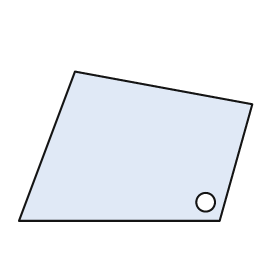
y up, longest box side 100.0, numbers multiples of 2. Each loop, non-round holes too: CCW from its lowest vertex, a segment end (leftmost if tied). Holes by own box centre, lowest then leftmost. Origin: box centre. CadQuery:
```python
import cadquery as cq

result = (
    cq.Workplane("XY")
    .moveTo(-50.0, -32.0)
    .lineTo(36.0, -32.0)
    .lineTo(50.0, 18.0)
    .lineTo(-26.0, 32.0)
    .close()
    .moveTo(30.0, -24.0)
    .circle(4.0)
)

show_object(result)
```